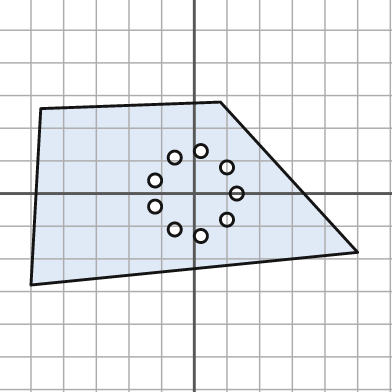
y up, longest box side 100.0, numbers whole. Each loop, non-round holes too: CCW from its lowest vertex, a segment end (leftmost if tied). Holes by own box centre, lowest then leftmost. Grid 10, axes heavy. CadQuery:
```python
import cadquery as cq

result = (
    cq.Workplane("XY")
    .moveTo(-50.0, -28.0)
    .lineTo(50.0, -18.0)
    .lineTo(8.0, 28.0)
    .lineTo(-47.0, 26.0)
    .close()
    .moveTo(2.0, -13.0)
    .circle(2.0)
    .moveTo(-6.0, -11.0)
    .circle(2.0)
    .moveTo(10.0, -8.0)
    .circle(2.0)
    .moveTo(-12.0, -4.0)
    .circle(2.0)
    .moveTo(13.0, 0.0)
    .circle(2.0)
    .moveTo(-12.0, 4.0)
    .circle(2.0)
    .moveTo(10.0, 8.0)
    .circle(2.0)
    .moveTo(-6.0, 11.0)
    .circle(2.0)
    .moveTo(2.0, 13.0)
    .circle(2.0)
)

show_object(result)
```